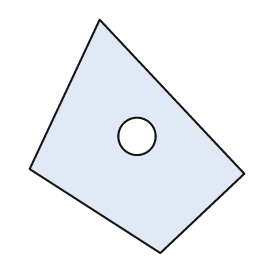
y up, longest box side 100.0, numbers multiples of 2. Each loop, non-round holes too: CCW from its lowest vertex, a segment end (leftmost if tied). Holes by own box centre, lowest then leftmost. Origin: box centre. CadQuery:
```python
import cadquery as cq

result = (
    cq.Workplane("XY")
    .moveTo(10.0, -50.0)
    .lineTo(46.0, -16.0)
    .lineTo(-16.0, 50.0)
    .lineTo(-46.0, -14.0)
    .close()
    .moveTo(0.0, 0.0)
    .circle(8.0)
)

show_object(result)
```